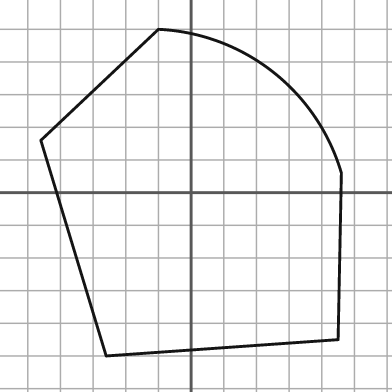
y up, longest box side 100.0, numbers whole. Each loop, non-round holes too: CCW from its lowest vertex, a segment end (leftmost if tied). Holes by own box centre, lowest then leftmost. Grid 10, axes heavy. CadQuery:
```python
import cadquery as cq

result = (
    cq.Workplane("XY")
    .moveTo(-26.0, -50.0)
    .lineTo(45.0, -45.0)
    .lineTo(46.0, 6.0)
    .threePointArc((25.0, 37.0), (-10.0, 50.0))
    .lineTo(-46.0, 16.0)
    .close()
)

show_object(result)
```